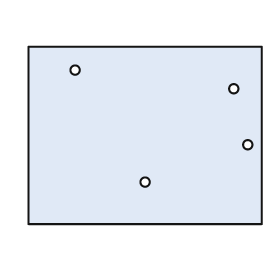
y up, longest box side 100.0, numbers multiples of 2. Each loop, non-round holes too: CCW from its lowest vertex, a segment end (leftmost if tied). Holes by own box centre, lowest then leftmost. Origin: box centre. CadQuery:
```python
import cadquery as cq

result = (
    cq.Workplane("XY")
    .moveTo(-50.0, -38.0)
    .lineTo(50.0, -38.0)
    .lineTo(50.0, 38.0)
    .lineTo(-50.0, 38.0)
    .close()
    .moveTo(0.0, -20.0)
    .circle(2.0)
    .moveTo(44.0, -4.0)
    .circle(2.0)
    .moveTo(38.0, 20.0)
    .circle(2.0)
    .moveTo(-30.0, 28.0)
    .circle(2.0)
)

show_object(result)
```